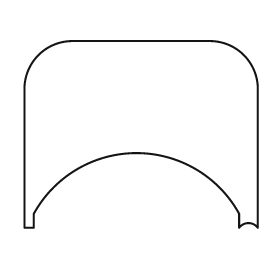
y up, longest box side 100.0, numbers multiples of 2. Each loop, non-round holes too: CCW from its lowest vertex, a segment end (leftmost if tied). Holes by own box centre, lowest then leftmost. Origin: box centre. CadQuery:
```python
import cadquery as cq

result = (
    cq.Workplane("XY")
    .moveTo(-50.0, -40.0)
    .lineTo(-46.0, -40.0)
    .lineTo(-46.0, -34.0)
    .threePointArc((-2.0, -8.0), (42.0, -34.0))
    .lineTo(42.0, -40.0)
    .threePointArc((46.0, -38.0), (50.0, -40.0))
    .lineTo(50.0, 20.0)
    .threePointArc((44.0, 34.0), (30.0, 40.0))
    .lineTo(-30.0, 40.0)
    .threePointArc((-44.0, 34.0), (-50.0, 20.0))
    .close()
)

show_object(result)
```